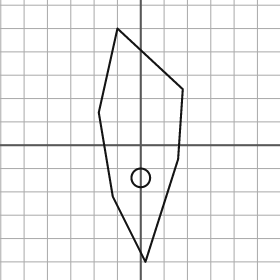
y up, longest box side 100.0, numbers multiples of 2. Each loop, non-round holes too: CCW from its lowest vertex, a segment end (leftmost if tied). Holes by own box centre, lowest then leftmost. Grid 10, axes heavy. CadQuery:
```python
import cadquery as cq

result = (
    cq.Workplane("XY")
    .moveTo(2.0, -50.0)
    .lineTo(16.0, -6.0)
    .lineTo(18.0, 24.0)
    .lineTo(-10.0, 50.0)
    .lineTo(-18.0, 14.0)
    .lineTo(-12.0, -22.0)
    .close()
    .moveTo(0.0, -14.0)
    .circle(4.0)
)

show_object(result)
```